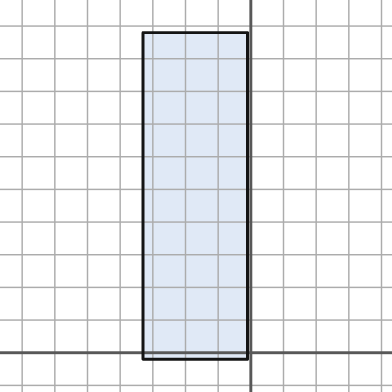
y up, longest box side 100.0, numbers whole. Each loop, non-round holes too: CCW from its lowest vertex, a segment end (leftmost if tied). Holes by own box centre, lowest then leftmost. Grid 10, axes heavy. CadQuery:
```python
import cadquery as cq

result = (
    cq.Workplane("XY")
    .moveTo(-33.0, -2.0)
    .lineTo(-1.0, -2.0)
    .lineTo(-1.0, 98.0)
    .lineTo(-33.0, 98.0)
    .close()
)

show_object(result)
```